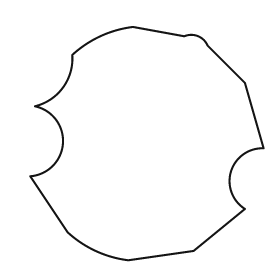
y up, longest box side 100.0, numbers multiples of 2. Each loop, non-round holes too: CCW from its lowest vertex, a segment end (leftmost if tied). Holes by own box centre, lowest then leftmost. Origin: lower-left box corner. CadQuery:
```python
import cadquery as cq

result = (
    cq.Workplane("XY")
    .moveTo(42.0, 0.0)
    .lineTo(70.0, 4.0)
    .lineTo(92.0, 22.0)
    .threePointArc((86.0, 38.0), (100.0, 48.0))
    .lineTo(92.0, 76.0)
    .lineTo(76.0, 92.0)
    .threePointArc((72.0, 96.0), (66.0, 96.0))
    .lineTo(44.0, 100.0)
    .threePointArc((30.0, 96.0), (18.0, 88.0))
    .threePointArc((14.0, 74.0), (2.0, 66.0))
    .threePointArc((14.0, 50.0), (0.0, 36.0))
    .lineTo(16.0, 12.0)
    .threePointArc((28.0, 4.0), (42.0, 0.0))
    .close()
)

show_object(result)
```